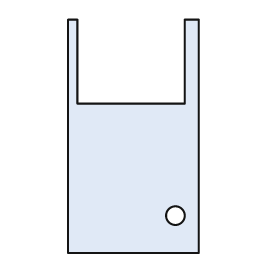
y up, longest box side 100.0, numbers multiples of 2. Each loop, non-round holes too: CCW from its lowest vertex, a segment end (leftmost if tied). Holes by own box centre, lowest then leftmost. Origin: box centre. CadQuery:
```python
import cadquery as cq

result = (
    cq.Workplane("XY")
    .moveTo(-28.0, -50.0)
    .lineTo(28.0, -50.0)
    .lineTo(28.0, 50.0)
    .lineTo(22.0, 50.0)
    .lineTo(22.0, 14.0)
    .lineTo(-24.0, 14.0)
    .lineTo(-24.0, 50.0)
    .lineTo(-28.0, 50.0)
    .close()
    .moveTo(18.0, -34.0)
    .circle(4.0)
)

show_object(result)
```